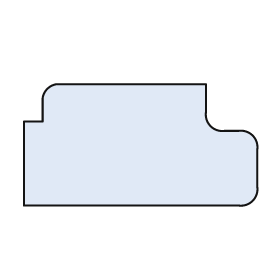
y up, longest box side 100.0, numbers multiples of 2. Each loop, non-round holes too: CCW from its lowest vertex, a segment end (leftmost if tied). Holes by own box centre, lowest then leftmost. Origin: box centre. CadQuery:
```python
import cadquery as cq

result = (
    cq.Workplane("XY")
    .moveTo(-50.0, -26.0)
    .lineTo(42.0, -26.0)
    .threePointArc((48.0, -24.0), (50.0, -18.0))
    .lineTo(50.0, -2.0)
    .threePointArc((48.0, 4.0), (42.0, 6.0))
    .lineTo(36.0, 6.0)
    .threePointArc((30.0, 8.0), (28.0, 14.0))
    .lineTo(28.0, 26.0)
    .lineTo(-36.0, 26.0)
    .threePointArc((-40.0, 24.0), (-42.0, 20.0))
    .lineTo(-42.0, 10.0)
    .lineTo(-50.0, 10.0)
    .close()
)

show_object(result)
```